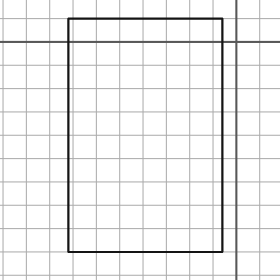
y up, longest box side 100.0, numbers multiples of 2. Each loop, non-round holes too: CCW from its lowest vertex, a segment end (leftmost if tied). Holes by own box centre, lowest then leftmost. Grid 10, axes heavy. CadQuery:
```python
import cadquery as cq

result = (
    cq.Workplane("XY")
    .moveTo(-72.0, -90.0)
    .lineTo(-6.0, -90.0)
    .lineTo(-6.0, 10.0)
    .lineTo(-72.0, 10.0)
    .close()
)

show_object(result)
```